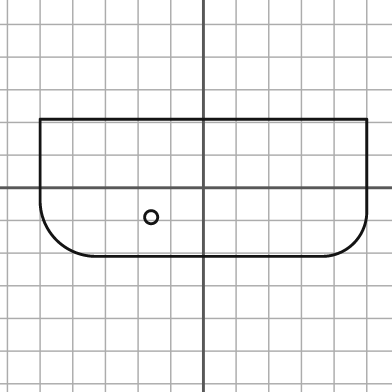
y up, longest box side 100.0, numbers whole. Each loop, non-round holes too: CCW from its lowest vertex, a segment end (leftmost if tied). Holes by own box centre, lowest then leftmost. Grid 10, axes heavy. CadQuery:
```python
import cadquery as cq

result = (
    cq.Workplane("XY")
    .moveTo(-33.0, -21.0)
    .lineTo(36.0, -21.0)
    .threePointArc((46.0, -17.0), (50.0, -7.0))
    .lineTo(50.0, 21.0)
    .lineTo(-50.0, 21.0)
    .lineTo(-50.0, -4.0)
    .threePointArc((-45.0, -16.0), (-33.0, -21.0))
    .close()
    .moveTo(-16.0, -9.0)
    .circle(2.0)
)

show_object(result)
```